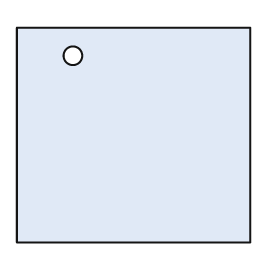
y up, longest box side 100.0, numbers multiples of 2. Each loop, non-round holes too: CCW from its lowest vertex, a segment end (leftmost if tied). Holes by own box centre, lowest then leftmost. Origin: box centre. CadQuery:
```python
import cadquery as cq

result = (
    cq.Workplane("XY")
    .moveTo(-50.0, -46.0)
    .lineTo(50.0, -46.0)
    .lineTo(50.0, 46.0)
    .lineTo(-50.0, 46.0)
    .close()
    .moveTo(-26.0, 34.0)
    .circle(4.0)
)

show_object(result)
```